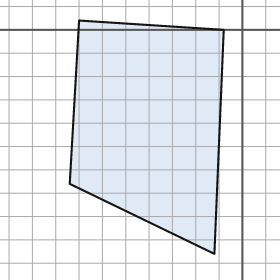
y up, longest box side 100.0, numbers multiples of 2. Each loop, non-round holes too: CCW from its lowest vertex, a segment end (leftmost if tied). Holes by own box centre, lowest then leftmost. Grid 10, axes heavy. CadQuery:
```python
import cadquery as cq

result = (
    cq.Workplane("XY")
    .moveTo(-12.0, -96.0)
    .lineTo(-8.0, 0.0)
    .lineTo(-70.0, 4.0)
    .lineTo(-74.0, -66.0)
    .close()
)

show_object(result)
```